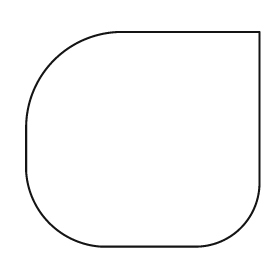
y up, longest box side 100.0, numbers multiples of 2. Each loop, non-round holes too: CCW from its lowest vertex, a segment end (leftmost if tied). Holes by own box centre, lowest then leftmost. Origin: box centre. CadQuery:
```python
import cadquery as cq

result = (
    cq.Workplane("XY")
    .moveTo(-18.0, -46.0)
    .lineTo(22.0, -46.0)
    .threePointArc((42.0, -38.0), (50.0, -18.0))
    .lineTo(50.0, 46.0)
    .lineTo(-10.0, 46.0)
    .threePointArc((-38.0, 34.0), (-50.0, 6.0))
    .lineTo(-50.0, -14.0)
    .threePointArc((-40.0, -36.0), (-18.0, -46.0))
    .close()
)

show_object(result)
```